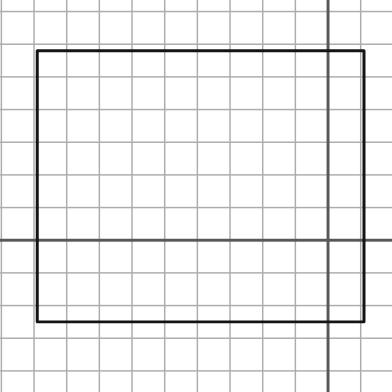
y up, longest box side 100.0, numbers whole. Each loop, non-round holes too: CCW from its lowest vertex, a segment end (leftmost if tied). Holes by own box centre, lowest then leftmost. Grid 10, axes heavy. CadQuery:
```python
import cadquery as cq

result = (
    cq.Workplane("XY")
    .moveTo(-89.0, -25.0)
    .lineTo(11.0, -25.0)
    .lineTo(11.0, 58.0)
    .lineTo(-89.0, 58.0)
    .close()
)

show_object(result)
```